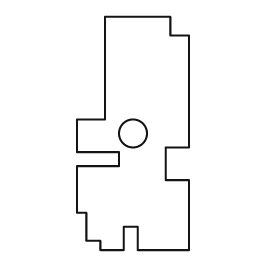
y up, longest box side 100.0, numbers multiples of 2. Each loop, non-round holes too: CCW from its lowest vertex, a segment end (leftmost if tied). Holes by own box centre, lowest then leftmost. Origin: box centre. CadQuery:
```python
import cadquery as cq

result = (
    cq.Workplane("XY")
    .moveTo(-14.0, -50.0)
    .lineTo(-4.0, -50.0)
    .lineTo(-4.0, -40.0)
    .lineTo(2.0, -40.0)
    .lineTo(2.0, -50.0)
    .lineTo(24.0, -50.0)
    .lineTo(24.0, -20.0)
    .lineTo(14.0, -20.0)
    .lineTo(14.0, -6.0)
    .lineTo(24.0, -6.0)
    .lineTo(24.0, 42.0)
    .lineTo(16.0, 42.0)
    .lineTo(16.0, 50.0)
    .lineTo(-12.0, 50.0)
    .lineTo(-12.0, 6.0)
    .lineTo(-24.0, 6.0)
    .lineTo(-24.0, -8.0)
    .lineTo(-6.0, -8.0)
    .lineTo(-6.0, -14.0)
    .lineTo(-24.0, -14.0)
    .lineTo(-24.0, -34.0)
    .lineTo(-20.0, -34.0)
    .lineTo(-20.0, -46.0)
    .lineTo(-14.0, -46.0)
    .close()
    .moveTo(0.0, 0.0)
    .circle(6.0)
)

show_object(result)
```